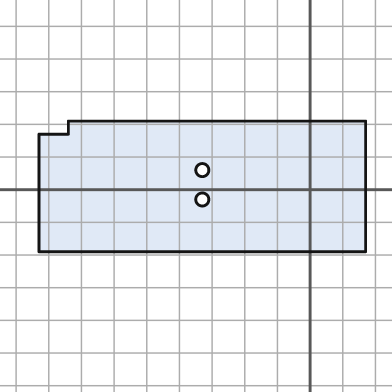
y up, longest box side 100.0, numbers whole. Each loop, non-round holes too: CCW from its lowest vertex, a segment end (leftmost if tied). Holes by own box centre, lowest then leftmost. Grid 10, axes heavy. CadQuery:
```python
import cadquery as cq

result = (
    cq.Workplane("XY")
    .moveTo(-83.0, -19.0)
    .lineTo(17.0, -19.0)
    .lineTo(17.0, 21.0)
    .lineTo(-74.0, 21.0)
    .lineTo(-74.0, 17.0)
    .lineTo(-83.0, 17.0)
    .close()
    .moveTo(-33.0, -3.0)
    .circle(2.0)
    .moveTo(-33.0, 6.0)
    .circle(2.0)
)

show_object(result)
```